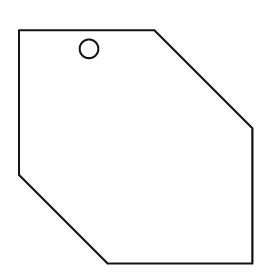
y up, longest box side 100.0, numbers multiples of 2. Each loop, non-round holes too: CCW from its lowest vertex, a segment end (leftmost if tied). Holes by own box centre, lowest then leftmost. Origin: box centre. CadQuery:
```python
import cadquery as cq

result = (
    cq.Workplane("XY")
    .moveTo(-12.0, -50.0)
    .lineTo(50.0, -50.0)
    .lineTo(50.0, 8.0)
    .lineTo(8.0, 50.0)
    .lineTo(-50.0, 50.0)
    .lineTo(-50.0, -12.0)
    .close()
    .moveTo(-20.0, 42.0)
    .circle(4.0)
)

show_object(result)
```